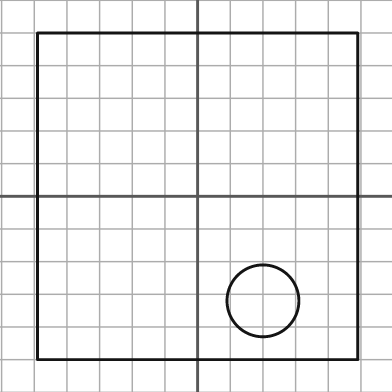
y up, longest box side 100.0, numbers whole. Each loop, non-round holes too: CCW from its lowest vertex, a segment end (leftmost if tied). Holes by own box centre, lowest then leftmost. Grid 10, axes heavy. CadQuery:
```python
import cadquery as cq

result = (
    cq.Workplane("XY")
    .moveTo(-49.0, -50.0)
    .lineTo(49.0, -50.0)
    .lineTo(49.0, 50.0)
    .lineTo(-49.0, 50.0)
    .close()
    .moveTo(20.0, -32.0)
    .circle(11.0)
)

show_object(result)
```